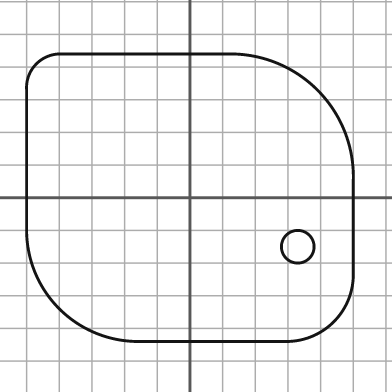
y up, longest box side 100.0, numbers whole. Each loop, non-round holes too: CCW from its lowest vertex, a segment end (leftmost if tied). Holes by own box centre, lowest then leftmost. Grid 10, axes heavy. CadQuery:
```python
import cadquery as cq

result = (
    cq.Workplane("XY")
    .moveTo(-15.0, -44.0)
    .lineTo(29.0, -44.0)
    .threePointArc((44.0, -38.0), (50.0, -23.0))
    .lineTo(50.0, 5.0)
    .threePointArc((39.0, 33.0), (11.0, 44.0))
    .lineTo(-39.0, 44.0)
    .threePointArc((-47.0, 41.0), (-50.0, 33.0))
    .lineTo(-50.0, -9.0)
    .threePointArc((-40.0, -34.0), (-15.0, -44.0))
    .close()
    .moveTo(33.0, -15.0)
    .circle(5.0)
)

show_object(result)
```